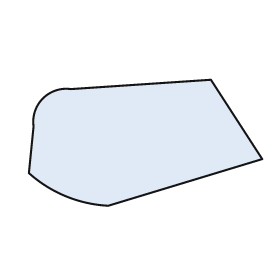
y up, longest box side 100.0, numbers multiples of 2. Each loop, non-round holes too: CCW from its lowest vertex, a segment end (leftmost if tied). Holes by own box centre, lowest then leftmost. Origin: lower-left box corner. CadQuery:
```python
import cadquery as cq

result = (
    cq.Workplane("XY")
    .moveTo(34.0, 0.0)
    .lineTo(100.0, 20.0)
    .lineTo(78.0, 54.0)
    .lineTo(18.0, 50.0)
    .threePointArc((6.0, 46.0), (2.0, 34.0))
    .lineTo(0.0, 14.0)
    .threePointArc((16.0, 4.0), (34.0, 0.0))
    .close()
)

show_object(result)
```